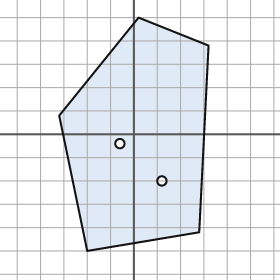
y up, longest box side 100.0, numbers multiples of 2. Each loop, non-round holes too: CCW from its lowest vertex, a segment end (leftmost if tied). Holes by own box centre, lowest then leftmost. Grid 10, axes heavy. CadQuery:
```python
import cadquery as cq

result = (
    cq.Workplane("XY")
    .moveTo(-20.0, -50.0)
    .lineTo(28.0, -42.0)
    .lineTo(32.0, 38.0)
    .lineTo(2.0, 50.0)
    .lineTo(-32.0, 8.0)
    .close()
    .moveTo(12.0, -20.0)
    .circle(2.0)
    .moveTo(-6.0, -4.0)
    .circle(2.0)
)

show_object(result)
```